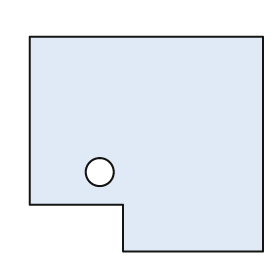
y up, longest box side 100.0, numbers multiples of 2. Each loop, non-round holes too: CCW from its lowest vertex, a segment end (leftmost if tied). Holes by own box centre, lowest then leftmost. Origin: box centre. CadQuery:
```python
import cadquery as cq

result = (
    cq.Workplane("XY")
    .moveTo(-10.0, -46.0)
    .lineTo(50.0, -46.0)
    .lineTo(50.0, 46.0)
    .lineTo(-50.0, 46.0)
    .lineTo(-50.0, -26.0)
    .lineTo(-10.0, -26.0)
    .close()
    .moveTo(-20.0, -12.0)
    .circle(6.0)
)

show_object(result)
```